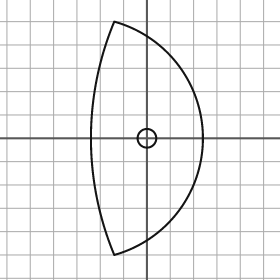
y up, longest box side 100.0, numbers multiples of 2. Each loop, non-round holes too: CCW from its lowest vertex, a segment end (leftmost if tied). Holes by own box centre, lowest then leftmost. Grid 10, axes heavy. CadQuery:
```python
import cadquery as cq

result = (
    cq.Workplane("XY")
    .moveTo(-14.0, -50.0)
    .threePointArc((24.0, 0.0), (-14.0, 50.0))
    .threePointArc((-24.0, 0.0), (-14.0, -50.0))
    .close()
    .moveTo(0.0, 0.0)
    .circle(4.0)
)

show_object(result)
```